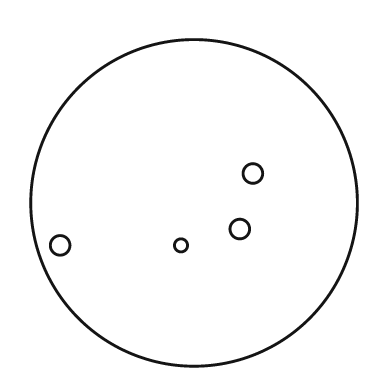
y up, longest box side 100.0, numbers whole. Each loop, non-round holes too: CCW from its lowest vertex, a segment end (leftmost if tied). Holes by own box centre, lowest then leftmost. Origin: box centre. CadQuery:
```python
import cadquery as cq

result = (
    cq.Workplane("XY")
    .moveTo(0.0, 0.0)
    .circle(50.0)
    .moveTo(-41.0, -13.0)
    .circle(3.0)
    .moveTo(-4.0, -13.0)
    .circle(2.0)
    .moveTo(14.0, -8.0)
    .circle(3.0)
    .moveTo(18.0, 9.0)
    .circle(3.0)
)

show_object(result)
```